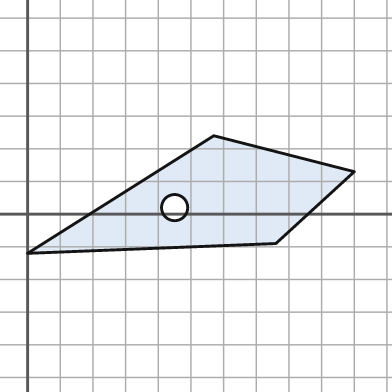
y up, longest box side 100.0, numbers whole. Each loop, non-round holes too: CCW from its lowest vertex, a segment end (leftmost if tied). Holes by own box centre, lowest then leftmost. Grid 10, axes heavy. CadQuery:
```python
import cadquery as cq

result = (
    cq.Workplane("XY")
    .moveTo(0.0, -12.0)
    .lineTo(76.0, -9.0)
    .lineTo(100.0, 13.0)
    .lineTo(57.0, 24.0)
    .close()
    .moveTo(45.0, 2.0)
    .circle(4.0)
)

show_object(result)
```